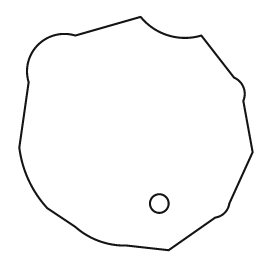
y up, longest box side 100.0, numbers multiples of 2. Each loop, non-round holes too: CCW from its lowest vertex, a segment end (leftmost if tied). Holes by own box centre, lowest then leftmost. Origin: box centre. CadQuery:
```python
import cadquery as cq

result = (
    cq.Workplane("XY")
    .moveTo(14.0, -50.0)
    .lineTo(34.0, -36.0)
    .threePointArc((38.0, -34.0), (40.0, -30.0))
    .lineTo(50.0, -8.0)
    .lineTo(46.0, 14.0)
    .threePointArc((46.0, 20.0), (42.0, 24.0))
    .lineTo(28.0, 42.0)
    .threePointArc((14.0, 42.0), (2.0, 50.0))
    .lineTo(-26.0, 42.0)
    .threePointArc((-42.0, 38.0), (-46.0, 22.0))
    .lineTo(-50.0, -6.0)
    .threePointArc((-46.0, -20.0), (-38.0, -32.0))
    .lineTo(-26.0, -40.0)
    .threePointArc((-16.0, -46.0), (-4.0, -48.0))
    .close()
    .moveTo(10.0, -30.0)
    .circle(4.0)
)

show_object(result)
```